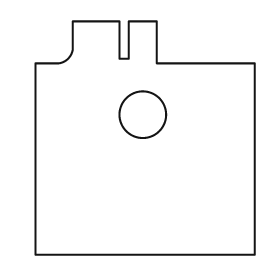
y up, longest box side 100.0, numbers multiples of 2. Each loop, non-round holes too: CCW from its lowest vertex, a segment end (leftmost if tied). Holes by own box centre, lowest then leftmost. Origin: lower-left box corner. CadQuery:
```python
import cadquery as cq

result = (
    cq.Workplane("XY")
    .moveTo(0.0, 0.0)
    .lineTo(94.0, 0.0)
    .lineTo(94.0, 82.0)
    .lineTo(52.0, 82.0)
    .lineTo(52.0, 100.0)
    .lineTo(40.0, 100.0)
    .lineTo(40.0, 84.0)
    .lineTo(36.0, 84.0)
    .lineTo(36.0, 100.0)
    .lineTo(16.0, 100.0)
    .lineTo(16.0, 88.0)
    .threePointArc((14.0, 84.0), (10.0, 82.0))
    .lineTo(0.0, 82.0)
    .close()
    .moveTo(46.0, 60.0)
    .circle(10.0)
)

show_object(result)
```